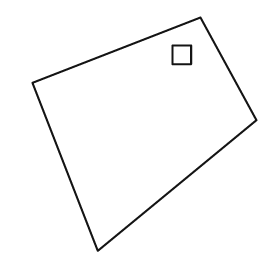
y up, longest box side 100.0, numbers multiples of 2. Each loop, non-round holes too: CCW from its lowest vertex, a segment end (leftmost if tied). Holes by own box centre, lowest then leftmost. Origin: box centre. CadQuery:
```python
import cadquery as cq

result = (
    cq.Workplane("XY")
    .moveTo(-20.0, -50.0)
    .lineTo(48.0, 6.0)
    .lineTo(24.0, 50.0)
    .lineTo(-48.0, 22.0)
    .close()
    .moveTo(12.0, 30.0)
    .lineTo(20.0, 30.0)
    .lineTo(20.0, 38.0)
    .lineTo(12.0, 38.0)
    .close()
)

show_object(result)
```